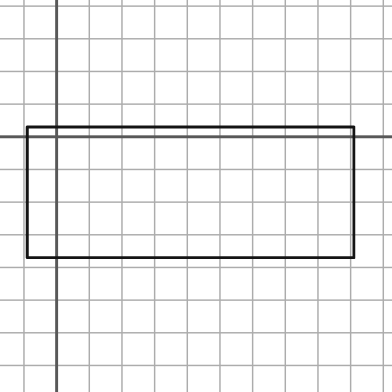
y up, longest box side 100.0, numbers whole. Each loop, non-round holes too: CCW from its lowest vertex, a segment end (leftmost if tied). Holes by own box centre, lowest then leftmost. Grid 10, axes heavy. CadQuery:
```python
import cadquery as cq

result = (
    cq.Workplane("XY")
    .moveTo(-9.0, -37.0)
    .lineTo(91.0, -37.0)
    .lineTo(91.0, 3.0)
    .lineTo(-9.0, 3.0)
    .close()
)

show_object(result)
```